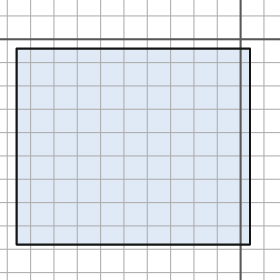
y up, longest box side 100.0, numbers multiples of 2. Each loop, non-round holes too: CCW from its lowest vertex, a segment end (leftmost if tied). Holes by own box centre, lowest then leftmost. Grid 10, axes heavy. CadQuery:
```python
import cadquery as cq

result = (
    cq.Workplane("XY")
    .moveTo(-96.0, -88.0)
    .lineTo(4.0, -88.0)
    .lineTo(4.0, -4.0)
    .lineTo(-96.0, -4.0)
    .close()
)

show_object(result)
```